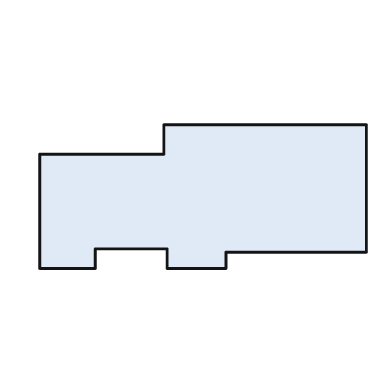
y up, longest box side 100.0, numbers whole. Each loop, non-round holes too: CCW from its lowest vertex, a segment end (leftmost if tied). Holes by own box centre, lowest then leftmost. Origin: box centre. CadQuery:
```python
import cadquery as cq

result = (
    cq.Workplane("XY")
    .moveTo(-50.0, -22.0)
    .lineTo(-33.0, -22.0)
    .lineTo(-33.0, -16.0)
    .lineTo(-11.0, -16.0)
    .lineTo(-11.0, -22.0)
    .lineTo(7.0, -22.0)
    .lineTo(7.0, -17.0)
    .lineTo(50.0, -17.0)
    .lineTo(50.0, 22.0)
    .lineTo(-12.0, 22.0)
    .lineTo(-12.0, 13.0)
    .lineTo(-50.0, 13.0)
    .close()
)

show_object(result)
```